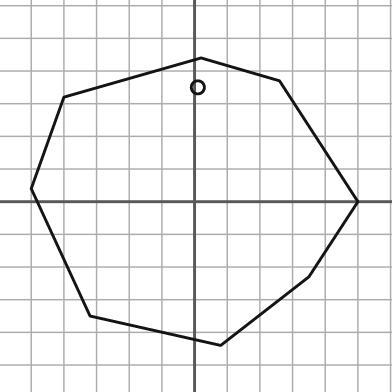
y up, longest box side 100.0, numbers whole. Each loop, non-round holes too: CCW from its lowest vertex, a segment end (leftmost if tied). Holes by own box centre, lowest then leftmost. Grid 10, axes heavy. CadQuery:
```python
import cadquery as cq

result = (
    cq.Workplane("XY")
    .moveTo(8.0, -44.0)
    .lineTo(35.0, -23.0)
    .lineTo(50.0, 0.0)
    .lineTo(26.0, 37.0)
    .lineTo(2.0, 44.0)
    .lineTo(-40.0, 32.0)
    .lineTo(-50.0, 4.0)
    .lineTo(-32.0, -35.0)
    .close()
    .moveTo(1.0, 35.0)
    .circle(2.0)
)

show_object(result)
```